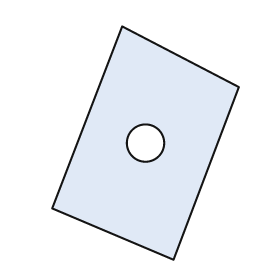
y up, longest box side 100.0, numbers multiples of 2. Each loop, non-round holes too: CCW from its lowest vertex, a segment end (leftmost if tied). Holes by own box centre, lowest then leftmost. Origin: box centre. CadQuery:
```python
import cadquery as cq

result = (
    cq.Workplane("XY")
    .moveTo(12.0, -50.0)
    .lineTo(40.0, 24.0)
    .lineTo(-10.0, 50.0)
    .lineTo(-40.0, -28.0)
    .close()
    .moveTo(0.0, 0.0)
    .circle(8.0)
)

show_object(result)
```